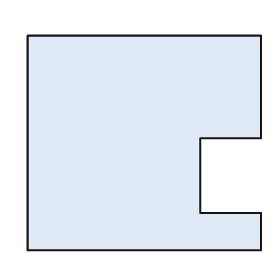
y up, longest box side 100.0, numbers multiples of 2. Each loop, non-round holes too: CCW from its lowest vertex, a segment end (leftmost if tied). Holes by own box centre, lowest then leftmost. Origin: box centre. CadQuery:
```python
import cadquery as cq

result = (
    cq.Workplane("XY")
    .moveTo(-50.0, -46.0)
    .lineTo(50.0, -46.0)
    .lineTo(50.0, -30.0)
    .lineTo(24.0, -30.0)
    .lineTo(24.0, 2.0)
    .lineTo(50.0, 2.0)
    .lineTo(50.0, 46.0)
    .lineTo(-50.0, 46.0)
    .close()
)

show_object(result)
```